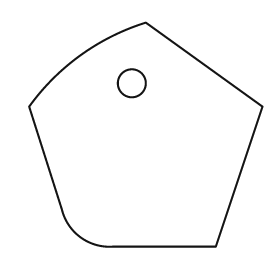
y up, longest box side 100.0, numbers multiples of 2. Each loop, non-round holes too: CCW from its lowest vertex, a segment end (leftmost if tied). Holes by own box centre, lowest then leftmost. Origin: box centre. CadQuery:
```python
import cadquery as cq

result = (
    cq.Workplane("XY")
    .moveTo(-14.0, -48.0)
    .lineTo(30.0, -48.0)
    .lineTo(50.0, 12.0)
    .lineTo(0.0, 48.0)
    .threePointArc((-28.0, 34.0), (-50.0, 12.0))
    .lineTo(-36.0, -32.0)
    .threePointArc((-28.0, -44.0), (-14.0, -48.0))
    .close()
    .moveTo(-6.0, 22.0)
    .circle(6.0)
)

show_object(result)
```